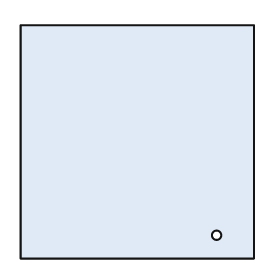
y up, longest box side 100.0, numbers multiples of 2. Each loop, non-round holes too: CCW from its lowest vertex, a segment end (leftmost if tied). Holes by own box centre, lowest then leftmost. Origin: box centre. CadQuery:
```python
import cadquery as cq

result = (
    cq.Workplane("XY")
    .moveTo(-50.0, -50.0)
    .lineTo(50.0, -50.0)
    .lineTo(50.0, 50.0)
    .lineTo(-50.0, 50.0)
    .close()
    .moveTo(34.0, -40.0)
    .circle(2.0)
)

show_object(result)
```